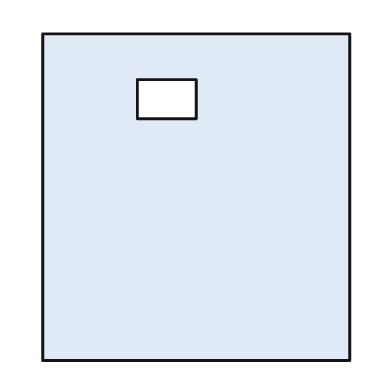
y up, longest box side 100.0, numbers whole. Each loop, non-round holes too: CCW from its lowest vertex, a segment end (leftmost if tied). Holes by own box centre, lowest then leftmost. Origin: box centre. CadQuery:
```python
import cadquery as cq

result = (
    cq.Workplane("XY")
    .moveTo(-47.0, -50.0)
    .lineTo(47.0, -50.0)
    .lineTo(47.0, 50.0)
    .lineTo(-47.0, 50.0)
    .close()
    .moveTo(-18.0, 24.0)
    .lineTo(0.0, 24.0)
    .lineTo(0.0, 36.0)
    .lineTo(-18.0, 36.0)
    .close()
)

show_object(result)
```